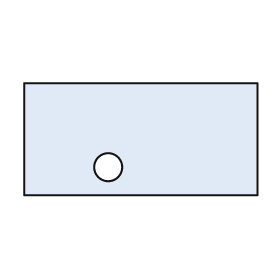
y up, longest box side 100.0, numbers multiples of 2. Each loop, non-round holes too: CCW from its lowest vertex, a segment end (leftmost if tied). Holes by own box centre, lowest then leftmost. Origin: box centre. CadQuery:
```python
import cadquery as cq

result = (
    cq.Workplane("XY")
    .moveTo(-50.0, -24.0)
    .lineTo(50.0, -24.0)
    .lineTo(50.0, 24.0)
    .lineTo(-50.0, 24.0)
    .close()
    .moveTo(-14.0, -12.0)
    .circle(6.0)
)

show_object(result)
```